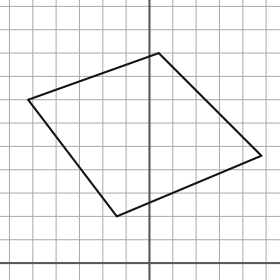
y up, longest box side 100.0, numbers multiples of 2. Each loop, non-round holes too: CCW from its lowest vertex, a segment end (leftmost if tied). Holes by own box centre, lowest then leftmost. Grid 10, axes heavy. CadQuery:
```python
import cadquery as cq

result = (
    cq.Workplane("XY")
    .moveTo(-14.0, 20.0)
    .lineTo(48.0, 46.0)
    .lineTo(4.0, 90.0)
    .lineTo(-52.0, 70.0)
    .close()
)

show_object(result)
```